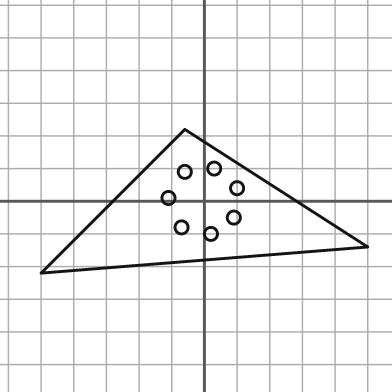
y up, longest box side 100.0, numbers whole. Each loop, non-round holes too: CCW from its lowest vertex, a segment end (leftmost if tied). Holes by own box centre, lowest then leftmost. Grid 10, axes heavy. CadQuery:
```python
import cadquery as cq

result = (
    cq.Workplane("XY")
    .moveTo(-50.0, -22.0)
    .lineTo(50.0, -14.0)
    .lineTo(-6.0, 22.0)
    .close()
    .moveTo(2.0, -10.0)
    .circle(2.0)
    .moveTo(-7.0, -8.0)
    .circle(2.0)
    .moveTo(9.0, -5.0)
    .circle(2.0)
    .moveTo(-11.0, 1.0)
    .circle(2.0)
    .moveTo(10.0, 4.0)
    .circle(2.0)
    .moveTo(-6.0, 9.0)
    .circle(2.0)
    .moveTo(3.0, 10.0)
    .circle(2.0)
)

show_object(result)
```